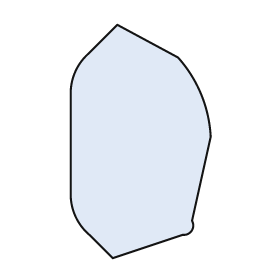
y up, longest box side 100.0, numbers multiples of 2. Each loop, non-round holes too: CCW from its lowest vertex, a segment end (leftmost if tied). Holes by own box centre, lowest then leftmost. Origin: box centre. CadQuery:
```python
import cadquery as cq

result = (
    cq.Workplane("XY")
    .moveTo(-12.0, -50.0)
    .lineTo(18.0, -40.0)
    .threePointArc((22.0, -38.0), (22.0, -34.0))
    .lineTo(30.0, 2.0)
    .threePointArc((26.0, 20.0), (16.0, 36.0))
    .lineTo(-10.0, 50.0)
    .lineTo(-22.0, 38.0)
    .threePointArc((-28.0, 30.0), (-30.0, 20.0))
    .lineTo(-30.0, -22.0)
    .threePointArc((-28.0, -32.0), (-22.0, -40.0))
    .close()
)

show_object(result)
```